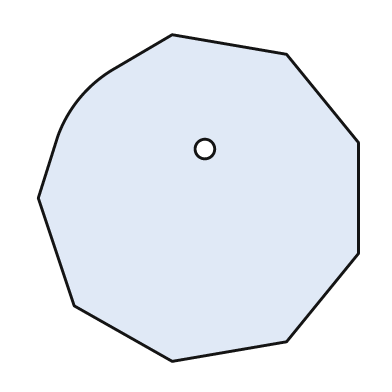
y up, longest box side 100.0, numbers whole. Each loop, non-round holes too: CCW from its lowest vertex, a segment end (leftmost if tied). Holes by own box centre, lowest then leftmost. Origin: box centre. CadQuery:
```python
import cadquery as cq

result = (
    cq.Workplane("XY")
    .moveTo(-8.0, -50.0)
    .lineTo(27.0, -44.0)
    .lineTo(49.0, -17.0)
    .lineTo(49.0, 17.0)
    .lineTo(27.0, 44.0)
    .lineTo(-8.0, 50.0)
    .lineTo(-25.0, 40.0)
    .threePointArc((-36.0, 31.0), (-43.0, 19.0))
    .lineTo(-49.0, 0.0)
    .lineTo(-38.0, -33.0)
    .close()
    .moveTo(2.0, 15.0)
    .circle(3.0)
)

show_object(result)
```